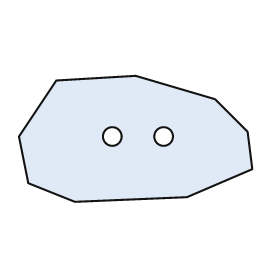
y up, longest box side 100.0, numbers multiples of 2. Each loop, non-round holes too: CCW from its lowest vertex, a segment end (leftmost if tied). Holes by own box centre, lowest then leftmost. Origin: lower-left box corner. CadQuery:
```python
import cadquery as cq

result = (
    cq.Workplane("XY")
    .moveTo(24.0, 0.0)
    .lineTo(72.0, 2.0)
    .lineTo(100.0, 14.0)
    .lineTo(98.0, 30.0)
    .lineTo(84.0, 44.0)
    .lineTo(50.0, 54.0)
    .lineTo(16.0, 52.0)
    .lineTo(0.0, 28.0)
    .lineTo(4.0, 8.0)
    .close()
    .moveTo(40.0, 28.0)
    .circle(4.0)
    .moveTo(62.0, 28.0)
    .circle(4.0)
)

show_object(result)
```